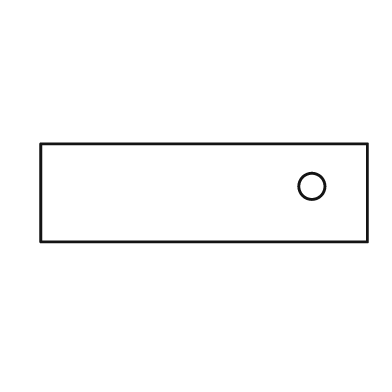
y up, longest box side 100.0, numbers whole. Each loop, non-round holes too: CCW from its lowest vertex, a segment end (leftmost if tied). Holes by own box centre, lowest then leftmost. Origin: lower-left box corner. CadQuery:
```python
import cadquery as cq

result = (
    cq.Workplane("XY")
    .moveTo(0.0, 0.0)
    .lineTo(100.0, 0.0)
    .lineTo(100.0, 30.0)
    .lineTo(0.0, 30.0)
    .close()
    .moveTo(83.0, 17.0)
    .circle(4.0)
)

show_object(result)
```